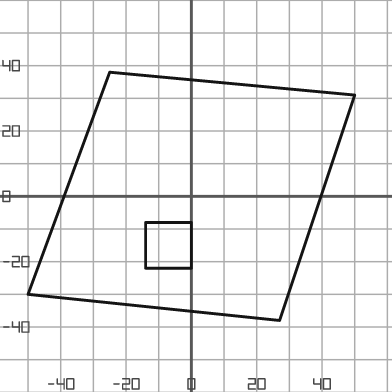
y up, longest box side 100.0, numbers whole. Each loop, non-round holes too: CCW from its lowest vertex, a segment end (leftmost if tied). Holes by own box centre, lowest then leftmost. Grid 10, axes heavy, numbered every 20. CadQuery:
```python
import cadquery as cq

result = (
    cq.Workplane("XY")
    .moveTo(27.0, -38.0)
    .lineTo(50.0, 31.0)
    .lineTo(-25.0, 38.0)
    .lineTo(-50.0, -30.0)
    .close()
    .moveTo(-14.0, -22.0)
    .lineTo(0.0, -22.0)
    .lineTo(0.0, -8.0)
    .lineTo(-14.0, -8.0)
    .close()
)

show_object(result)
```